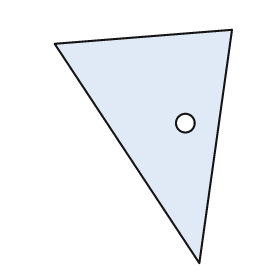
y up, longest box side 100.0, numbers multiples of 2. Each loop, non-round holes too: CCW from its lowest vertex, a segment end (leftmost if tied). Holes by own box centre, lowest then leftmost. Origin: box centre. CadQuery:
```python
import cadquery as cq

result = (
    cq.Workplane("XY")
    .moveTo(24.0, -50.0)
    .lineTo(38.0, 50.0)
    .lineTo(-38.0, 44.0)
    .close()
    .moveTo(18.0, 10.0)
    .circle(4.0)
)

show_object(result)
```